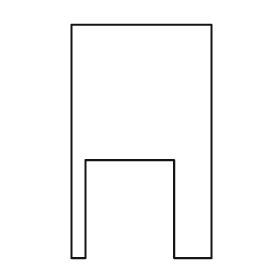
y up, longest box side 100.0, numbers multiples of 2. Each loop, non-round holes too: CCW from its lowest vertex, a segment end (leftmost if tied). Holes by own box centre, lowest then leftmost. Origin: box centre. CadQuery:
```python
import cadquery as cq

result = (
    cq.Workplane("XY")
    .moveTo(-30.0, -50.0)
    .lineTo(-24.0, -50.0)
    .lineTo(-24.0, -8.0)
    .lineTo(14.0, -8.0)
    .lineTo(14.0, -50.0)
    .lineTo(30.0, -50.0)
    .lineTo(30.0, 50.0)
    .lineTo(-30.0, 50.0)
    .close()
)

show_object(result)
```